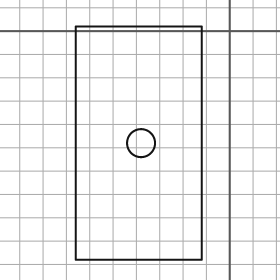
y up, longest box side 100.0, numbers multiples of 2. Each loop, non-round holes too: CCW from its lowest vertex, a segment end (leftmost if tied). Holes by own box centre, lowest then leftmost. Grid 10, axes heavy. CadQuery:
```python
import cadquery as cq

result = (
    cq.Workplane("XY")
    .moveTo(-66.0, -98.0)
    .lineTo(-12.0, -98.0)
    .lineTo(-12.0, 2.0)
    .lineTo(-66.0, 2.0)
    .close()
    .moveTo(-38.0, -48.0)
    .circle(6.0)
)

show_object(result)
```